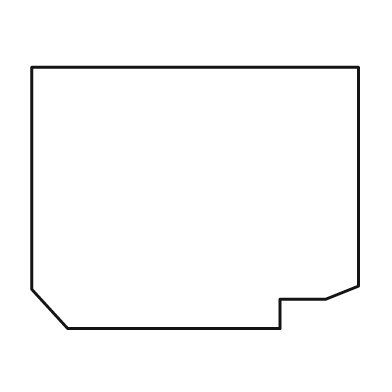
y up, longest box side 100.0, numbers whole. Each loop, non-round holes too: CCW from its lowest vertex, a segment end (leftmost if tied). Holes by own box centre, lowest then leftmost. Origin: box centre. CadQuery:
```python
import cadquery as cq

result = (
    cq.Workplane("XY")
    .moveTo(-39.0, -40.0)
    .lineTo(26.0, -40.0)
    .lineTo(26.0, -31.0)
    .lineTo(40.0, -31.0)
    .lineTo(50.0, -27.0)
    .lineTo(50.0, 40.0)
    .lineTo(-50.0, 40.0)
    .lineTo(-50.0, -28.0)
    .close()
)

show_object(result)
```